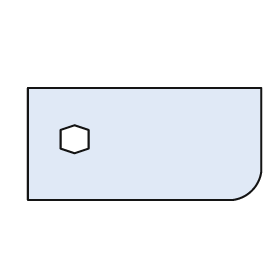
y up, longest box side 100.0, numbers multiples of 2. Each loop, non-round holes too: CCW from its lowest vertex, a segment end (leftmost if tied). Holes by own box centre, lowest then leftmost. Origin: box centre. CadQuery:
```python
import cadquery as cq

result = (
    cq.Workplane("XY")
    .moveTo(-50.0, -24.0)
    .lineTo(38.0, -24.0)
    .threePointArc((46.0, -20.0), (50.0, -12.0))
    .lineTo(50.0, 24.0)
    .lineTo(-50.0, 24.0)
    .close()
    .moveTo(-30.0, -4.0)
    .lineTo(-24.0, -2.0)
    .lineTo(-24.0, 6.0)
    .lineTo(-30.0, 8.0)
    .lineTo(-36.0, 6.0)
    .lineTo(-36.0, -2.0)
    .close()
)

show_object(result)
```